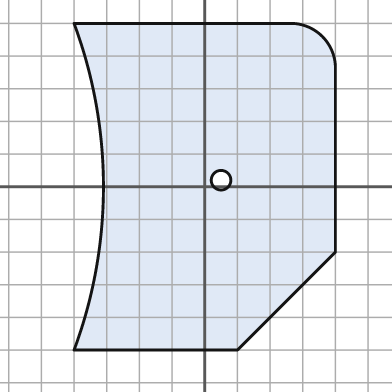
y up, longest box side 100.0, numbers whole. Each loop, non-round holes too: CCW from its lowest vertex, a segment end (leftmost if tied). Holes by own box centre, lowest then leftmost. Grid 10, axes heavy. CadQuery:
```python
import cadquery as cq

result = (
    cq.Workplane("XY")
    .moveTo(-40.0, -50.0)
    .lineTo(10.0, -50.0)
    .lineTo(40.0, -20.0)
    .lineTo(40.0, 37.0)
    .threePointArc((36.0, 46.0), (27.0, 50.0))
    .lineTo(-40.0, 50.0)
    .threePointArc((-31.0, 0.0), (-40.0, -50.0))
    .close()
    .moveTo(5.0, 2.0)
    .circle(3.0)
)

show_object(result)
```